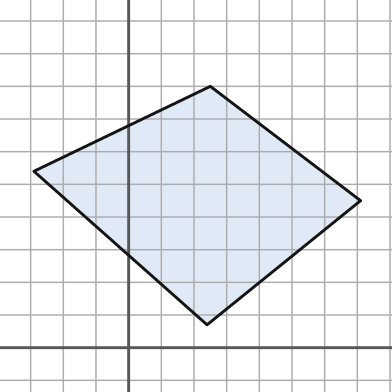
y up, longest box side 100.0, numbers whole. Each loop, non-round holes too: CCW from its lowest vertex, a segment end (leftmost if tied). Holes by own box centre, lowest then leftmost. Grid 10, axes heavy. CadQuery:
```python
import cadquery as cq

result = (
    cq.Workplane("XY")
    .moveTo(24.0, 7.0)
    .lineTo(71.0, 45.0)
    .lineTo(25.0, 80.0)
    .lineTo(-29.0, 54.0)
    .close()
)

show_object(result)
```